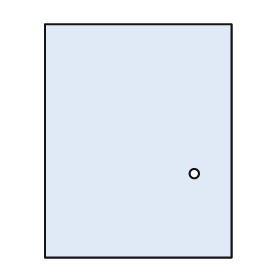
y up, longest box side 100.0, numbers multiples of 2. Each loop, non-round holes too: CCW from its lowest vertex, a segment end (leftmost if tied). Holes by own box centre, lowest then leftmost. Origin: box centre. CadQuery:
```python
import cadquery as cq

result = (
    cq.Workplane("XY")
    .moveTo(-40.0, -50.0)
    .lineTo(40.0, -50.0)
    .lineTo(40.0, 50.0)
    .lineTo(-40.0, 50.0)
    .close()
    .moveTo(24.0, -14.0)
    .circle(2.0)
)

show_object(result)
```